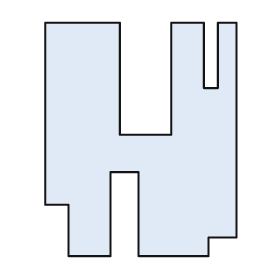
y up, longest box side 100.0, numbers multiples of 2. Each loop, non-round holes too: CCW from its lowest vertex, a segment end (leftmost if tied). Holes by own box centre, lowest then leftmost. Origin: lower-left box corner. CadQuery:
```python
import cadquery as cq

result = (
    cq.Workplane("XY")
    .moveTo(10.0, 0.0)
    .lineTo(28.0, 0.0)
    .lineTo(28.0, 36.0)
    .lineTo(40.0, 36.0)
    .lineTo(40.0, 0.0)
    .lineTo(70.0, 0.0)
    .lineTo(70.0, 8.0)
    .lineTo(82.0, 8.0)
    .lineTo(82.0, 100.0)
    .lineTo(74.0, 100.0)
    .lineTo(74.0, 72.0)
    .lineTo(68.0, 72.0)
    .lineTo(68.0, 100.0)
    .lineTo(54.0, 100.0)
    .lineTo(54.0, 52.0)
    .lineTo(32.0, 52.0)
    .lineTo(32.0, 100.0)
    .lineTo(0.0, 100.0)
    .lineTo(0.0, 22.0)
    .lineTo(10.0, 22.0)
    .close()
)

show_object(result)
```